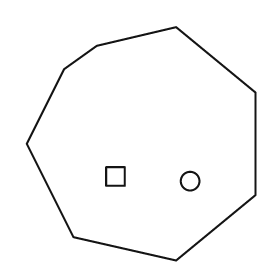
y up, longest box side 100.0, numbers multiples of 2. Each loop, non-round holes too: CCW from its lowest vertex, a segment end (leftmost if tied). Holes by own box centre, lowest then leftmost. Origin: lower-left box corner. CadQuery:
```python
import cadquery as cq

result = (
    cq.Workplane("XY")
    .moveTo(64.0, 0.0)
    .lineTo(98.0, 28.0)
    .lineTo(98.0, 72.0)
    .lineTo(64.0, 100.0)
    .lineTo(30.0, 92.0)
    .lineTo(16.0, 82.0)
    .lineTo(0.0, 50.0)
    .lineTo(20.0, 10.0)
    .close()
    .moveTo(70.0, 34.0)
    .circle(4.0)
    .moveTo(34.0, 32.0)
    .lineTo(42.0, 32.0)
    .lineTo(42.0, 40.0)
    .lineTo(34.0, 40.0)
    .close()
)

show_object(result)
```